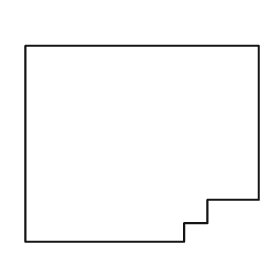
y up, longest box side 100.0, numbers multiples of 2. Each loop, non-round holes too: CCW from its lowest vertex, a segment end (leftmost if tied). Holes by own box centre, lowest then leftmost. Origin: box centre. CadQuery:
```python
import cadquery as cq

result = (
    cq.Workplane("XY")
    .moveTo(-50.0, -42.0)
    .lineTo(18.0, -42.0)
    .lineTo(18.0, -34.0)
    .lineTo(28.0, -34.0)
    .lineTo(28.0, -24.0)
    .lineTo(50.0, -24.0)
    .lineTo(50.0, 42.0)
    .lineTo(-50.0, 42.0)
    .close()
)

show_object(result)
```